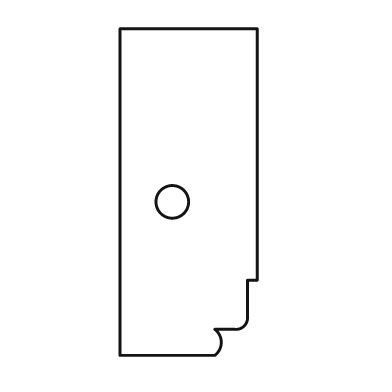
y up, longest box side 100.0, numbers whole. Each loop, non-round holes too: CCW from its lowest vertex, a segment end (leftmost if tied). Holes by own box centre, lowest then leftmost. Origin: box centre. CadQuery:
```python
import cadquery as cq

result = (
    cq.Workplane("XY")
    .moveTo(-21.0, -50.0)
    .lineTo(8.0, -50.0)
    .threePointArc((10.0, -46.0), (8.0, -42.0))
    .lineTo(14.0, -42.0)
    .threePointArc((17.0, -41.0), (18.0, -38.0))
    .lineTo(18.0, -27.0)
    .lineTo(21.0, -27.0)
    .lineTo(21.0, 50.0)
    .lineTo(-21.0, 50.0)
    .close()
    .moveTo(-5.0, -3.0)
    .circle(5.0)
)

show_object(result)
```